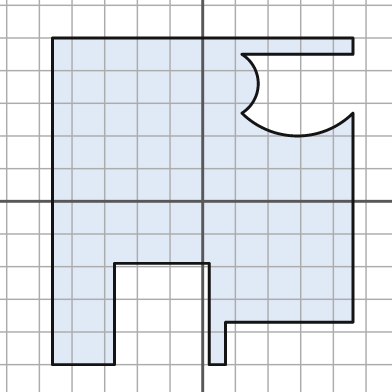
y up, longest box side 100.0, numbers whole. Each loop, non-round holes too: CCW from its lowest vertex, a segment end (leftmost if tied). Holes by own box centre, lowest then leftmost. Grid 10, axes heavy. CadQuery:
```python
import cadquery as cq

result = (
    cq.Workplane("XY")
    .moveTo(-46.0, -50.0)
    .lineTo(-27.0, -50.0)
    .lineTo(-27.0, -19.0)
    .lineTo(2.0, -19.0)
    .lineTo(2.0, -50.0)
    .lineTo(7.0, -50.0)
    .lineTo(7.0, -37.0)
    .lineTo(46.0, -37.0)
    .lineTo(46.0, 27.0)
    .threePointArc((29.0, 20.0), (12.0, 27.0))
    .threePointArc((17.0, 36.0), (12.0, 45.0))
    .lineTo(46.0, 45.0)
    .lineTo(46.0, 50.0)
    .lineTo(-46.0, 50.0)
    .close()
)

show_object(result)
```